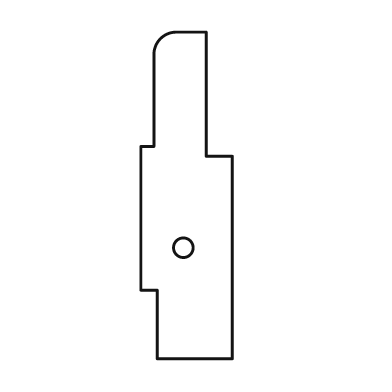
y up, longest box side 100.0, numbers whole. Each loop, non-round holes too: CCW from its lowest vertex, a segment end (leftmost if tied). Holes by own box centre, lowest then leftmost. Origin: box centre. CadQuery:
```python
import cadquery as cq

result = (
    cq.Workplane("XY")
    .moveTo(-9.0, -50.0)
    .lineTo(14.0, -50.0)
    .lineTo(14.0, 12.0)
    .lineTo(6.0, 12.0)
    .lineTo(6.0, 50.0)
    .lineTo(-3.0, 50.0)
    .threePointArc((-8.0, 48.0), (-10.0, 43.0))
    .lineTo(-10.0, 15.0)
    .lineTo(-14.0, 15.0)
    .lineTo(-14.0, -29.0)
    .lineTo(-9.0, -29.0)
    .close()
    .moveTo(-1.0, -16.0)
    .circle(3.0)
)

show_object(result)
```